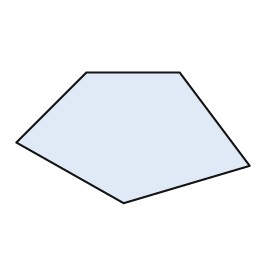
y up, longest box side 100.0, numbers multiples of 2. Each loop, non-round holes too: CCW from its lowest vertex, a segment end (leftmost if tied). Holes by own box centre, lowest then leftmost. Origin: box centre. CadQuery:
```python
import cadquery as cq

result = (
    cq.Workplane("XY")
    .moveTo(-4.0, -28.0)
    .lineTo(50.0, -12.0)
    .lineTo(20.0, 28.0)
    .lineTo(-20.0, 28.0)
    .lineTo(-50.0, -2.0)
    .close()
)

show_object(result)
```